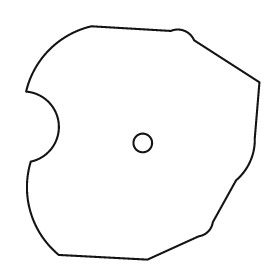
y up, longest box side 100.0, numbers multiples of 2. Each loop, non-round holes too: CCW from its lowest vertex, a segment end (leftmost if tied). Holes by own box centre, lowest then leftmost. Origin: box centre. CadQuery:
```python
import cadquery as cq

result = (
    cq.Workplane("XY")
    .moveTo(2.0, -50.0)
    .lineTo(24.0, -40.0)
    .threePointArc((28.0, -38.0), (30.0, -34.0))
    .lineTo(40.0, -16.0)
    .threePointArc((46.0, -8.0), (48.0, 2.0))
    .lineTo(50.0, 26.0)
    .lineTo(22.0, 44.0)
    .threePointArc((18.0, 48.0), (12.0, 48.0))
    .lineTo(-22.0, 50.0)
    .threePointArc((-40.0, 40.0), (-50.0, 22.0))
    .threePointArc((-36.0, 8.0), (-48.0, -8.0))
    .threePointArc((-48.0, -30.0), (-36.0, -48.0))
    .close()
    .moveTo(0.0, 0.0)
    .circle(4.0)
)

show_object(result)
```